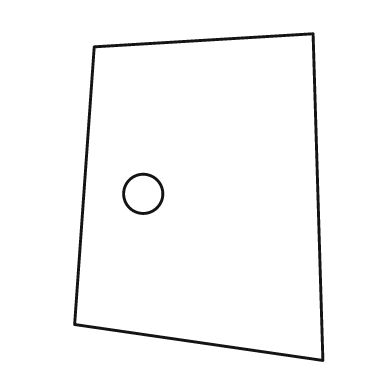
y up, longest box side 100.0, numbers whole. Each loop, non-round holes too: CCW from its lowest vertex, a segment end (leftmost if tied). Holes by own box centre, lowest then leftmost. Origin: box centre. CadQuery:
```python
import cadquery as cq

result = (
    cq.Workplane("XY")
    .moveTo(38.0, -50.0)
    .lineTo(35.0, 50.0)
    .lineTo(-32.0, 46.0)
    .lineTo(-38.0, -39.0)
    .close()
    .moveTo(-17.0, 1.0)
    .circle(6.0)
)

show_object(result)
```